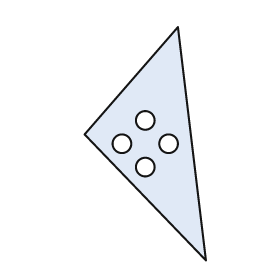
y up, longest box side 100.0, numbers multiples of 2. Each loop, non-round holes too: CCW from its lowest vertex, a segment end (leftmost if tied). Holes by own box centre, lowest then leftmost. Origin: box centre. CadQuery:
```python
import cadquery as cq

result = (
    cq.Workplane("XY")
    .moveTo(26.0, -50.0)
    .lineTo(14.0, 50.0)
    .lineTo(-26.0, 4.0)
    .close()
    .moveTo(0.0, -10.0)
    .circle(4.0)
    .moveTo(-10.0, 0.0)
    .circle(4.0)
    .moveTo(10.0, 0.0)
    .circle(4.0)
    .moveTo(0.0, 10.0)
    .circle(4.0)
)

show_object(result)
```